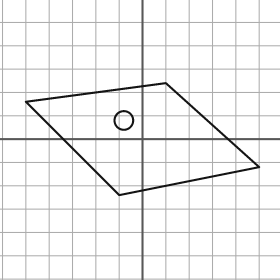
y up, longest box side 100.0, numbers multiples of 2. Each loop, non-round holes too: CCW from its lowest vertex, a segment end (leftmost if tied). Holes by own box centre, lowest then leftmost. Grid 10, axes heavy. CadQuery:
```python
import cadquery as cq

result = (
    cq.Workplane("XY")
    .moveTo(-10.0, -24.0)
    .lineTo(50.0, -12.0)
    .lineTo(10.0, 24.0)
    .lineTo(-50.0, 16.0)
    .close()
    .moveTo(-8.0, 8.0)
    .circle(4.0)
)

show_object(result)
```